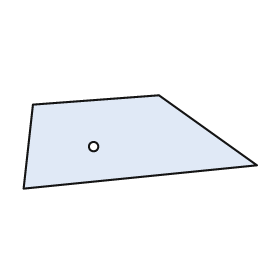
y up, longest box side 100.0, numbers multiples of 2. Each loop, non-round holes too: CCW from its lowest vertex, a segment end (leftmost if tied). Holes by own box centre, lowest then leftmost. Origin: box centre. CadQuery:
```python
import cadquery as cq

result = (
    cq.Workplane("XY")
    .moveTo(-50.0, -20.0)
    .lineTo(50.0, -10.0)
    .lineTo(8.0, 20.0)
    .lineTo(-46.0, 16.0)
    .close()
    .moveTo(-20.0, -2.0)
    .circle(2.0)
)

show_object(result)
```